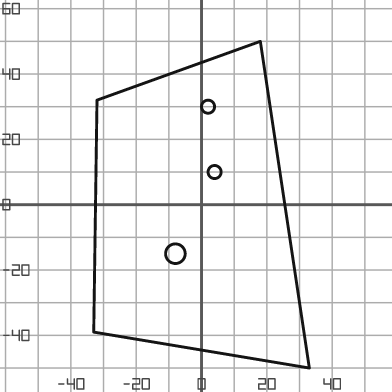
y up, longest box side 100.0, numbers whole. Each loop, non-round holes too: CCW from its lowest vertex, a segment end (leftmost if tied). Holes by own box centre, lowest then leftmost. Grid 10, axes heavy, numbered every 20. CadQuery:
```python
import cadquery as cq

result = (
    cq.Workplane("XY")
    .moveTo(33.0, -50.0)
    .lineTo(18.0, 50.0)
    .lineTo(-32.0, 32.0)
    .lineTo(-33.0, -39.0)
    .close()
    .moveTo(-8.0, -15.0)
    .circle(3.0)
    .moveTo(4.0, 10.0)
    .circle(2.0)
    .moveTo(2.0, 30.0)
    .circle(2.0)
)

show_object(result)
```